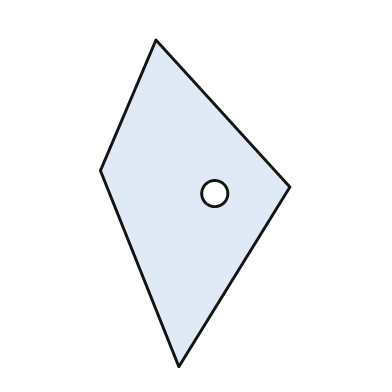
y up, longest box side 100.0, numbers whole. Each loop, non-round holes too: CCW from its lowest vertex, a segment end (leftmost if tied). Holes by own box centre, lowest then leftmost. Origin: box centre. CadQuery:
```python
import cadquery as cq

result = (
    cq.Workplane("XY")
    .moveTo(-5.0, -50.0)
    .lineTo(29.0, 5.0)
    .lineTo(-12.0, 50.0)
    .lineTo(-29.0, 10.0)
    .close()
    .moveTo(6.0, 3.0)
    .circle(4.0)
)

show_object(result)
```